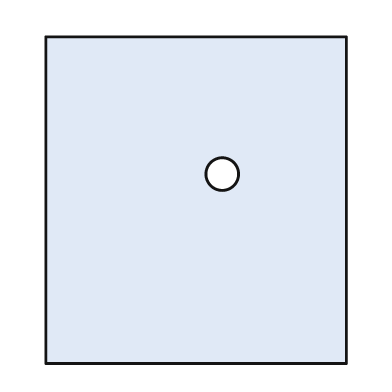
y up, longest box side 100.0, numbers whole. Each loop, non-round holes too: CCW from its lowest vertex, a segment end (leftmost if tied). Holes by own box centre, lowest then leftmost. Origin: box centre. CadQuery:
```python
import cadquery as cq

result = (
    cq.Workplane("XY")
    .moveTo(-46.0, -50.0)
    .lineTo(46.0, -50.0)
    .lineTo(46.0, 50.0)
    .lineTo(-46.0, 50.0)
    .close()
    .moveTo(8.0, 8.0)
    .circle(5.0)
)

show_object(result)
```